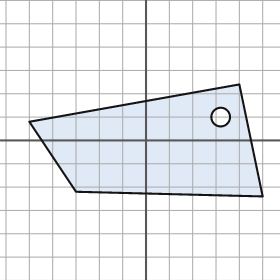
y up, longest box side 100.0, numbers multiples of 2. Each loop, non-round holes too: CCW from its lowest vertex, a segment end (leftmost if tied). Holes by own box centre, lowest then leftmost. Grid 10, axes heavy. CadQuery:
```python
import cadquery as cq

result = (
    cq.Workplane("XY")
    .moveTo(50.0, -24.0)
    .lineTo(40.0, 24.0)
    .lineTo(-50.0, 8.0)
    .lineTo(-30.0, -22.0)
    .close()
    .moveTo(32.0, 10.0)
    .circle(4.0)
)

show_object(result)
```